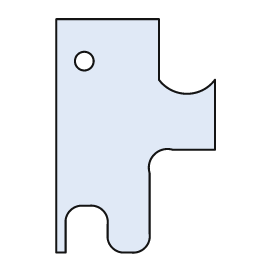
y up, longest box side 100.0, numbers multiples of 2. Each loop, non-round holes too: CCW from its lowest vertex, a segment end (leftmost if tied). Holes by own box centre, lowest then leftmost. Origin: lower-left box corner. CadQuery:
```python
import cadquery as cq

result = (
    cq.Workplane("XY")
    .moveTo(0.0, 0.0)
    .lineTo(4.0, 0.0)
    .lineTo(4.0, 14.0)
    .threePointArc((6.0, 18.0), (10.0, 20.0))
    .lineTo(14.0, 20.0)
    .threePointArc((20.0, 18.0), (22.0, 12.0))
    .lineTo(22.0, 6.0)
    .threePointArc((24.0, 2.0), (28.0, 0.0))
    .lineTo(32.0, 0.0)
    .threePointArc((38.0, 2.0), (40.0, 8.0))
    .lineTo(40.0, 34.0)
    .threePointArc((42.0, 42.0), (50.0, 44.0))
    .lineTo(68.0, 44.0)
    .lineTo(68.0, 74.0)
    .threePointArc((56.0, 68.0), (44.0, 74.0))
    .lineTo(44.0, 100.0)
    .lineTo(0.0, 100.0)
    .close()
    .moveTo(12.0, 82.0)
    .circle(4.0)
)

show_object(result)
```